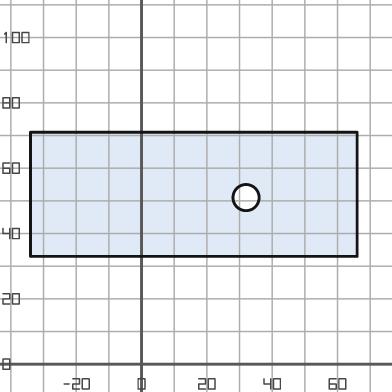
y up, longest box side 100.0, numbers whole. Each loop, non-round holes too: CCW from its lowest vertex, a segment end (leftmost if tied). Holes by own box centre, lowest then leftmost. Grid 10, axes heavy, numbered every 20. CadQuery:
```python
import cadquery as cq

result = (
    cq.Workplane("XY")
    .moveTo(-34.0, 33.0)
    .lineTo(66.0, 33.0)
    .lineTo(66.0, 71.0)
    .lineTo(-34.0, 71.0)
    .close()
    .moveTo(32.0, 51.0)
    .circle(4.0)
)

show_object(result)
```